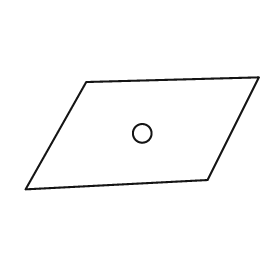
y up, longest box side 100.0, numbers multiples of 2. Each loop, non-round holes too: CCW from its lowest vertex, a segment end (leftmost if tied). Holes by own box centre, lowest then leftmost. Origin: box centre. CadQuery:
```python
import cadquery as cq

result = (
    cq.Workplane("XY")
    .moveTo(-50.0, -24.0)
    .lineTo(28.0, -20.0)
    .lineTo(50.0, 24.0)
    .lineTo(-24.0, 22.0)
    .close()
    .moveTo(0.0, 0.0)
    .circle(4.0)
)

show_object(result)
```